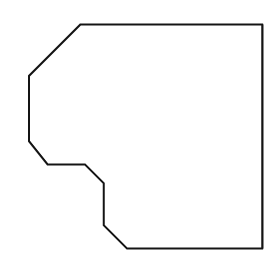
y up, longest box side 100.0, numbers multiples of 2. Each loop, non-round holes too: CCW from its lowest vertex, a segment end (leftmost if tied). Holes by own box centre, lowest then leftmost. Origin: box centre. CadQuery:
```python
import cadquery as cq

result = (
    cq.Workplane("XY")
    .moveTo(-8.0, -48.0)
    .lineTo(50.0, -48.0)
    .lineTo(50.0, 48.0)
    .lineTo(-28.0, 48.0)
    .lineTo(-50.0, 26.0)
    .lineTo(-50.0, -2.0)
    .lineTo(-42.0, -12.0)
    .lineTo(-26.0, -12.0)
    .lineTo(-18.0, -20.0)
    .lineTo(-18.0, -38.0)
    .close()
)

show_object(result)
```